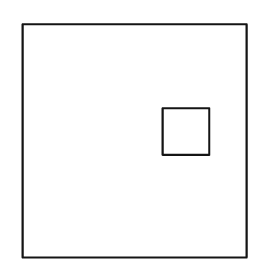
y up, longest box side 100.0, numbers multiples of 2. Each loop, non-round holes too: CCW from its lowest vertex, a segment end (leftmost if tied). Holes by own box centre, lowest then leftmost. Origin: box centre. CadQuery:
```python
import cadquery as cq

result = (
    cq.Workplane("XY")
    .moveTo(-48.0, -50.0)
    .lineTo(48.0, -50.0)
    .lineTo(48.0, 50.0)
    .lineTo(-48.0, 50.0)
    .close()
    .moveTo(12.0, -6.0)
    .lineTo(32.0, -6.0)
    .lineTo(32.0, 14.0)
    .lineTo(12.0, 14.0)
    .close()
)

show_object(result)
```